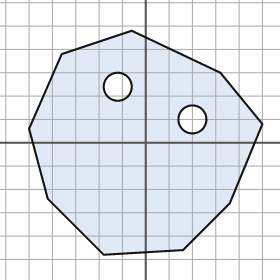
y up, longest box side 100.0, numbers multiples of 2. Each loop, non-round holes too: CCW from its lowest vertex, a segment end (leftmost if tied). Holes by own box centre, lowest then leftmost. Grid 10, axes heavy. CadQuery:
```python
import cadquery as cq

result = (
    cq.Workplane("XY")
    .moveTo(-18.0, -48.0)
    .lineTo(16.0, -46.0)
    .lineTo(36.0, -26.0)
    .lineTo(50.0, 8.0)
    .lineTo(32.0, 30.0)
    .lineTo(-6.0, 48.0)
    .lineTo(-36.0, 38.0)
    .lineTo(-50.0, 6.0)
    .lineTo(-42.0, -24.0)
    .close()
    .moveTo(20.0, 10.0)
    .circle(6.0)
    .moveTo(-12.0, 24.0)
    .circle(6.0)
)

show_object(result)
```